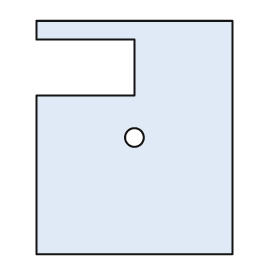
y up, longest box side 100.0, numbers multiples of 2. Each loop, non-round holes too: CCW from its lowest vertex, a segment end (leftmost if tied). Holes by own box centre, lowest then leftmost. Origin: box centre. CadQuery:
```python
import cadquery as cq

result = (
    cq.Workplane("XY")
    .moveTo(-42.0, -50.0)
    .lineTo(42.0, -50.0)
    .lineTo(42.0, 50.0)
    .lineTo(-42.0, 50.0)
    .lineTo(-42.0, 42.0)
    .lineTo(0.0, 42.0)
    .lineTo(0.0, 18.0)
    .lineTo(-42.0, 18.0)
    .close()
    .moveTo(0.0, 0.0)
    .circle(4.0)
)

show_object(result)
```